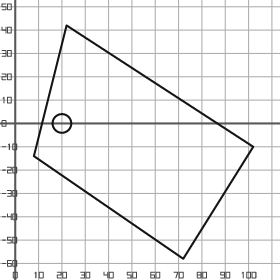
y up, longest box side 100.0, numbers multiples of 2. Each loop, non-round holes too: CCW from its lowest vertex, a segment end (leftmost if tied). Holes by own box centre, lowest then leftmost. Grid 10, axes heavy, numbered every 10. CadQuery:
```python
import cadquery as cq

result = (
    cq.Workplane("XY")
    .moveTo(72.0, -58.0)
    .lineTo(102.0, -10.0)
    .lineTo(22.0, 42.0)
    .lineTo(8.0, -14.0)
    .close()
    .moveTo(20.0, 0.0)
    .circle(4.0)
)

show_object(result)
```